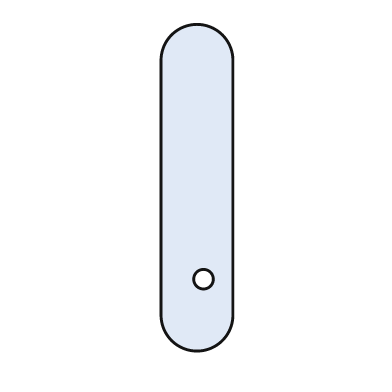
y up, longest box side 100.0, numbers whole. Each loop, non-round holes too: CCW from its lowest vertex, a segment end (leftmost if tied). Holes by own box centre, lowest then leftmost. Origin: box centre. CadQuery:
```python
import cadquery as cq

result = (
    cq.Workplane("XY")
    .moveTo(-11.0, -39.0)
    .threePointArc((0.0, -50.0), (11.0, -39.0))
    .lineTo(11.0, 39.0)
    .threePointArc((0.0, 50.0), (-11.0, 39.0))
    .close()
    .moveTo(2.0, -28.0)
    .circle(3.0)
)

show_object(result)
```